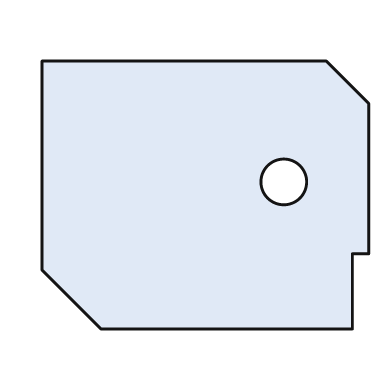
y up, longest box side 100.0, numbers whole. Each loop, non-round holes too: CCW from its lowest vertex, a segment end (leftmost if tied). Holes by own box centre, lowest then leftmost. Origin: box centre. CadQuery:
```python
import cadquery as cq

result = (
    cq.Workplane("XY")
    .moveTo(-32.0, -41.0)
    .lineTo(45.0, -41.0)
    .lineTo(45.0, -18.0)
    .lineTo(50.0, -18.0)
    .lineTo(50.0, 28.0)
    .lineTo(37.0, 41.0)
    .lineTo(-50.0, 41.0)
    .lineTo(-50.0, -23.0)
    .close()
    .moveTo(24.0, 4.0)
    .circle(7.0)
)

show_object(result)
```